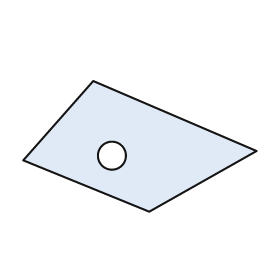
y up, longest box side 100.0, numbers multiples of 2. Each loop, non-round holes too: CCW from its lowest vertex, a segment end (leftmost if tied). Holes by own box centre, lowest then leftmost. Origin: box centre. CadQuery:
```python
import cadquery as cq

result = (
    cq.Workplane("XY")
    .moveTo(4.0, -28.0)
    .lineTo(50.0, -2.0)
    .lineTo(-20.0, 28.0)
    .lineTo(-50.0, -6.0)
    .close()
    .moveTo(-12.0, -4.0)
    .circle(6.0)
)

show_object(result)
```